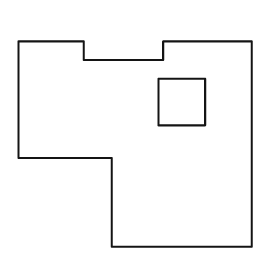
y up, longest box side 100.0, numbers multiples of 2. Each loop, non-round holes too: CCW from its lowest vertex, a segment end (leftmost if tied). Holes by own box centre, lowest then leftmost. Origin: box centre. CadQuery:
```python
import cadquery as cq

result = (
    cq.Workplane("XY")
    .moveTo(-10.0, -44.0)
    .lineTo(50.0, -44.0)
    .lineTo(50.0, 44.0)
    .lineTo(12.0, 44.0)
    .lineTo(12.0, 36.0)
    .lineTo(-22.0, 36.0)
    .lineTo(-22.0, 44.0)
    .lineTo(-50.0, 44.0)
    .lineTo(-50.0, -6.0)
    .lineTo(-10.0, -6.0)
    .close()
    .moveTo(10.0, 8.0)
    .lineTo(30.0, 8.0)
    .lineTo(30.0, 28.0)
    .lineTo(10.0, 28.0)
    .close()
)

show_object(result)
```